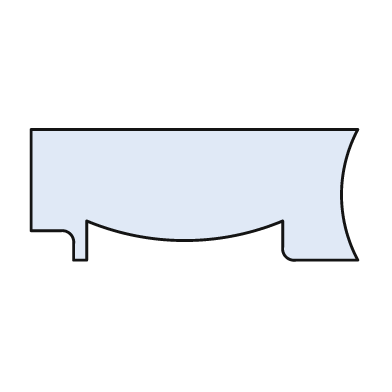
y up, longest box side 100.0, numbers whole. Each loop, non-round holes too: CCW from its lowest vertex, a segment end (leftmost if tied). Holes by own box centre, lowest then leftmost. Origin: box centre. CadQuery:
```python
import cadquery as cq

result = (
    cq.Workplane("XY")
    .moveTo(-37.0, -20.0)
    .lineTo(-33.0, -20.0)
    .lineTo(-33.0, -8.0)
    .threePointArc((-3.0, -14.0), (27.0, -8.0))
    .lineTo(27.0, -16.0)
    .threePointArc((28.0, -19.0), (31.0, -20.0))
    .lineTo(50.0, -20.0)
    .threePointArc((45.0, 0.0), (50.0, 20.0))
    .lineTo(-50.0, 20.0)
    .lineTo(-50.0, -11.0)
    .lineTo(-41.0, -11.0)
    .threePointArc((-38.0, -12.0), (-37.0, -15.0))
    .close()
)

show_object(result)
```